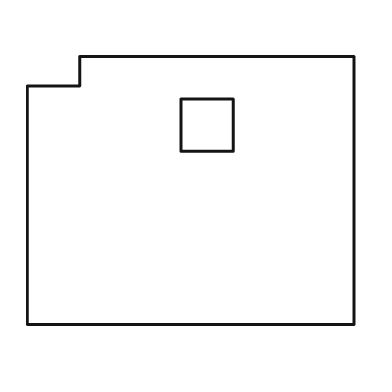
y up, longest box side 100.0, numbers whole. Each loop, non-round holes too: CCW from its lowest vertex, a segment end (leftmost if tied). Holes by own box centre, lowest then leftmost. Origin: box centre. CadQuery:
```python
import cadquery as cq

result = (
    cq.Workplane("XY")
    .moveTo(-50.0, -41.0)
    .lineTo(50.0, -41.0)
    .lineTo(50.0, 41.0)
    .lineTo(-34.0, 41.0)
    .lineTo(-34.0, 32.0)
    .lineTo(-50.0, 32.0)
    .close()
    .moveTo(-3.0, 12.0)
    .lineTo(13.0, 12.0)
    .lineTo(13.0, 28.0)
    .lineTo(-3.0, 28.0)
    .close()
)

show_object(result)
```